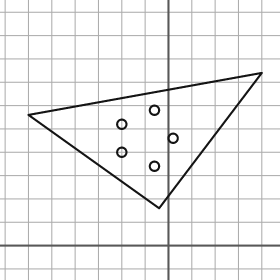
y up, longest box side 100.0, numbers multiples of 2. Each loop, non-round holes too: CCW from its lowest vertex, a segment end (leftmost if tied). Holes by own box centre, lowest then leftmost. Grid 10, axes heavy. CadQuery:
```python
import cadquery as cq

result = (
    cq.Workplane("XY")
    .moveTo(-4.0, 16.0)
    .lineTo(40.0, 74.0)
    .lineTo(-60.0, 56.0)
    .close()
    .moveTo(-6.0, 34.0)
    .circle(2.0)
    .moveTo(-20.0, 40.0)
    .circle(2.0)
    .moveTo(2.0, 46.0)
    .circle(2.0)
    .moveTo(-20.0, 52.0)
    .circle(2.0)
    .moveTo(-6.0, 58.0)
    .circle(2.0)
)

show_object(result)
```